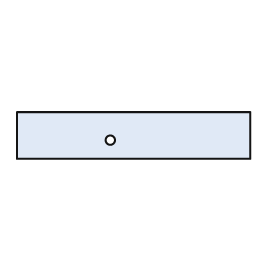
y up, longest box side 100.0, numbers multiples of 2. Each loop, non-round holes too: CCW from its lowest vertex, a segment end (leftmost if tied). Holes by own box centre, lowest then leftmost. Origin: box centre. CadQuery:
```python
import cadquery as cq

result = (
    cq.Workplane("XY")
    .moveTo(-50.0, -10.0)
    .lineTo(50.0, -10.0)
    .lineTo(50.0, 10.0)
    .lineTo(-50.0, 10.0)
    .close()
    .moveTo(-10.0, -2.0)
    .circle(2.0)
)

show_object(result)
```